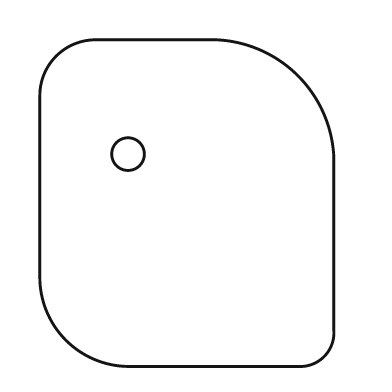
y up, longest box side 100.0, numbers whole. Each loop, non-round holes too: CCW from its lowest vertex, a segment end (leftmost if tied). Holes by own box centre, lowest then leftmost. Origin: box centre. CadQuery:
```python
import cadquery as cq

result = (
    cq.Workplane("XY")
    .moveTo(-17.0, -50.0)
    .lineTo(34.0, -50.0)
    .threePointArc((42.0, -47.0), (45.0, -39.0))
    .lineTo(45.0, 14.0)
    .threePointArc((34.0, 39.0), (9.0, 50.0))
    .lineTo(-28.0, 50.0)
    .threePointArc((-40.0, 45.0), (-45.0, 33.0))
    .lineTo(-45.0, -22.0)
    .threePointArc((-37.0, -42.0), (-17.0, -50.0))
    .close()
    .moveTo(-18.0, 15.0)
    .circle(5.0)
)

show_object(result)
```